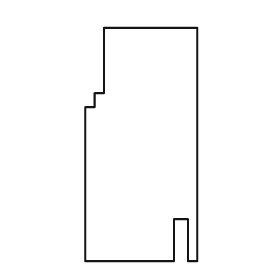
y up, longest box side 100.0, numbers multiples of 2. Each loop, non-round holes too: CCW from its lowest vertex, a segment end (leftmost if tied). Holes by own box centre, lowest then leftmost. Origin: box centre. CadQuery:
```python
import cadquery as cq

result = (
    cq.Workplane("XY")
    .moveTo(-24.0, -50.0)
    .lineTo(14.0, -50.0)
    .lineTo(14.0, -32.0)
    .lineTo(20.0, -32.0)
    .lineTo(20.0, -50.0)
    .lineTo(24.0, -50.0)
    .lineTo(24.0, 50.0)
    .lineTo(-16.0, 50.0)
    .lineTo(-16.0, 22.0)
    .lineTo(-20.0, 22.0)
    .lineTo(-20.0, 16.0)
    .lineTo(-24.0, 16.0)
    .close()
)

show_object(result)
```